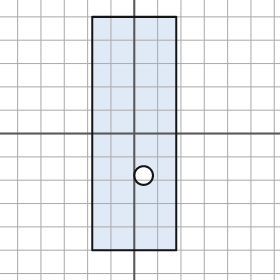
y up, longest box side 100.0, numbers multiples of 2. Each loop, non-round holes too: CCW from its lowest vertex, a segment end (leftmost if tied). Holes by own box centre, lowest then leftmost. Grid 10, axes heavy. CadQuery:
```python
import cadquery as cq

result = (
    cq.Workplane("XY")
    .moveTo(-18.0, -50.0)
    .lineTo(18.0, -50.0)
    .lineTo(18.0, 50.0)
    .lineTo(-18.0, 50.0)
    .close()
    .moveTo(4.0, -18.0)
    .circle(4.0)
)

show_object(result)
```